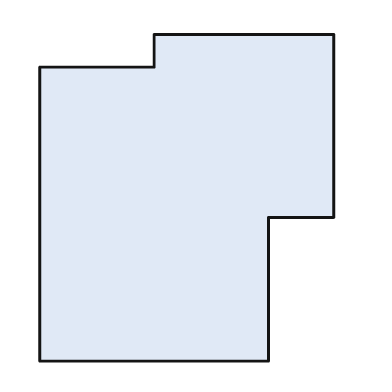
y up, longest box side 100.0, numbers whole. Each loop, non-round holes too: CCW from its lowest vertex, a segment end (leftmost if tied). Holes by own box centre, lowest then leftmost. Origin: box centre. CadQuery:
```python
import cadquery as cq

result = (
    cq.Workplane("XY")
    .moveTo(-45.0, -50.0)
    .lineTo(25.0, -50.0)
    .lineTo(25.0, -6.0)
    .lineTo(45.0, -6.0)
    .lineTo(45.0, 50.0)
    .lineTo(-10.0, 50.0)
    .lineTo(-10.0, 40.0)
    .lineTo(-45.0, 40.0)
    .close()
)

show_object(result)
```